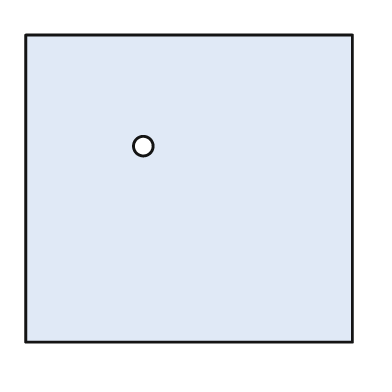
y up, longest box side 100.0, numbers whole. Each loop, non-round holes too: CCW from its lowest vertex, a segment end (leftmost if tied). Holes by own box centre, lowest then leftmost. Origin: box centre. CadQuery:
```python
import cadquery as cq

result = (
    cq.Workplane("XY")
    .moveTo(-50.0, -47.0)
    .lineTo(50.0, -47.0)
    .lineTo(50.0, 47.0)
    .lineTo(-50.0, 47.0)
    .close()
    .moveTo(-14.0, 13.0)
    .circle(3.0)
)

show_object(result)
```